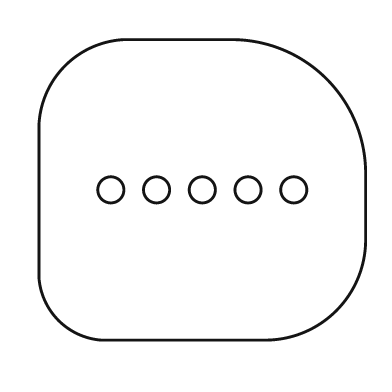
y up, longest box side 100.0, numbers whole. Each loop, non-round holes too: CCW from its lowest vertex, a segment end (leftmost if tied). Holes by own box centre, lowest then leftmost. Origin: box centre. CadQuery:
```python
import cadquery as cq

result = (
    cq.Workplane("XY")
    .moveTo(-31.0, -46.0)
    .lineTo(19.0, -46.0)
    .threePointArc((41.0, -37.0), (50.0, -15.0))
    .lineTo(50.0, 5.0)
    .threePointArc((38.0, 34.0), (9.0, 46.0))
    .lineTo(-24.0, 46.0)
    .threePointArc((-42.0, 38.0), (-50.0, 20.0))
    .lineTo(-50.0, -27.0)
    .threePointArc((-44.0, -40.0), (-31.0, -46.0))
    .close()
    .moveTo(-28.0, 0.0)
    .circle(4.0)
    .moveTo(-14.0, 0.0)
    .circle(4.0)
    .moveTo(0.0, 0.0)
    .circle(4.0)
    .moveTo(14.0, 0.0)
    .circle(4.0)
    .moveTo(28.0, 0.0)
    .circle(4.0)
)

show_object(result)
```